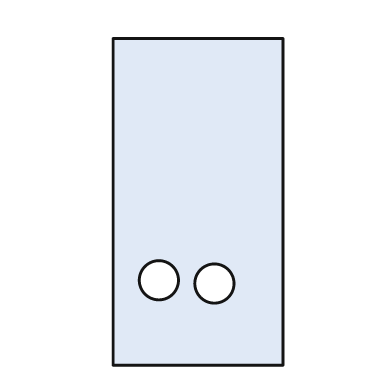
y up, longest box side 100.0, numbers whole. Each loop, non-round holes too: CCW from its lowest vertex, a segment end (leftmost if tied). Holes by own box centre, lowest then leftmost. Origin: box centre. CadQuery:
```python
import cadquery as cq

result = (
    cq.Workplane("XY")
    .moveTo(-26.0, -50.0)
    .lineTo(26.0, -50.0)
    .lineTo(26.0, 50.0)
    .lineTo(-26.0, 50.0)
    .close()
    .moveTo(5.0, -25.0)
    .circle(6.0)
    .moveTo(-12.0, -24.0)
    .circle(6.0)
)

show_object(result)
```